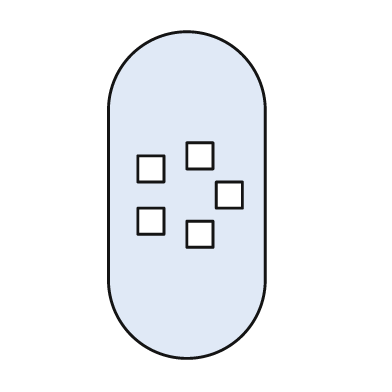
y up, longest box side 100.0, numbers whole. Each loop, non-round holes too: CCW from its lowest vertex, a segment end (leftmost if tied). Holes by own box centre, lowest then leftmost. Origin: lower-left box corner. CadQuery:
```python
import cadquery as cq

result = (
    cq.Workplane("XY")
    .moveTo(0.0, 24.0)
    .threePointArc((24.0, 0.0), (48.0, 24.0))
    .lineTo(48.0, 76.0)
    .threePointArc((24.0, 100.0), (0.0, 76.0))
    .close()
    .moveTo(24.0, 34.0)
    .lineTo(32.0, 34.0)
    .lineTo(32.0, 42.0)
    .lineTo(24.0, 42.0)
    .close()
    .moveTo(9.0, 38.0)
    .lineTo(17.0, 38.0)
    .lineTo(17.0, 46.0)
    .lineTo(9.0, 46.0)
    .close()
    .moveTo(33.0, 46.0)
    .lineTo(41.0, 46.0)
    .lineTo(41.0, 54.0)
    .lineTo(33.0, 54.0)
    .close()
    .moveTo(9.0, 54.0)
    .lineTo(17.0, 54.0)
    .lineTo(17.0, 62.0)
    .lineTo(9.0, 62.0)
    .close()
    .moveTo(24.0, 58.0)
    .lineTo(32.0, 58.0)
    .lineTo(32.0, 66.0)
    .lineTo(24.0, 66.0)
    .close()
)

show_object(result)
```